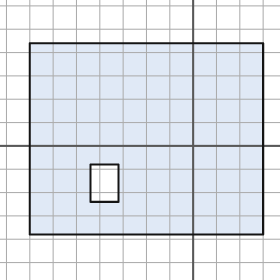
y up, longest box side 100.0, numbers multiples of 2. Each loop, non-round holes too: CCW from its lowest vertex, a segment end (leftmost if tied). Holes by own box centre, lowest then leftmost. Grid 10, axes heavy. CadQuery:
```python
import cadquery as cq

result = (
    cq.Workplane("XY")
    .moveTo(-70.0, -38.0)
    .lineTo(30.0, -38.0)
    .lineTo(30.0, 44.0)
    .lineTo(-70.0, 44.0)
    .close()
    .moveTo(-44.0, -24.0)
    .lineTo(-32.0, -24.0)
    .lineTo(-32.0, -8.0)
    .lineTo(-44.0, -8.0)
    .close()
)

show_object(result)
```